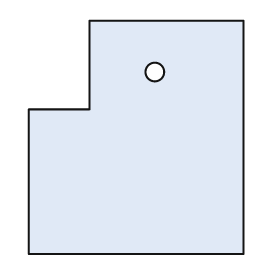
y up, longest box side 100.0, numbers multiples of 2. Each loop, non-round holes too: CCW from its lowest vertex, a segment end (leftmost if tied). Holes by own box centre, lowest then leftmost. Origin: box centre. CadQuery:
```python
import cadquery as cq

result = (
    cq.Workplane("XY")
    .moveTo(-46.0, -50.0)
    .lineTo(46.0, -50.0)
    .lineTo(46.0, 50.0)
    .lineTo(-20.0, 50.0)
    .lineTo(-20.0, 12.0)
    .lineTo(-46.0, 12.0)
    .close()
    .moveTo(8.0, 28.0)
    .circle(4.0)
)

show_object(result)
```